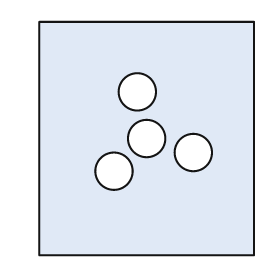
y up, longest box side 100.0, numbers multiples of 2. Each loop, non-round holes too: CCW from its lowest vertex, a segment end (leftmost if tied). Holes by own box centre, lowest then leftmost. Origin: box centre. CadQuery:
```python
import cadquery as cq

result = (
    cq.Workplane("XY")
    .moveTo(-46.0, -50.0)
    .lineTo(46.0, -50.0)
    .lineTo(46.0, 50.0)
    .lineTo(-46.0, 50.0)
    .close()
    .moveTo(-14.0, -14.0)
    .circle(8.0)
    .moveTo(20.0, -6.0)
    .circle(8.0)
    .moveTo(0.0, 0.0)
    .circle(8.0)
    .moveTo(-4.0, 20.0)
    .circle(8.0)
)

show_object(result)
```